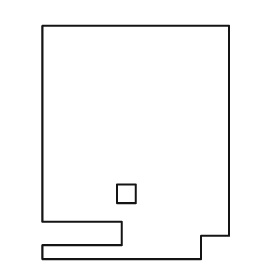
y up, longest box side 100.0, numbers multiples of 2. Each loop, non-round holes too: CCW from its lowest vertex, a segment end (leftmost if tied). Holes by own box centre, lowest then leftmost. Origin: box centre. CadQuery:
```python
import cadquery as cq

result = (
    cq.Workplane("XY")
    .moveTo(-40.0, -50.0)
    .lineTo(28.0, -50.0)
    .lineTo(28.0, -40.0)
    .lineTo(40.0, -40.0)
    .lineTo(40.0, 50.0)
    .lineTo(-40.0, 50.0)
    .lineTo(-40.0, -34.0)
    .lineTo(-6.0, -34.0)
    .lineTo(-6.0, -44.0)
    .lineTo(-40.0, -44.0)
    .close()
    .moveTo(-8.0, -26.0)
    .lineTo(0.0, -26.0)
    .lineTo(0.0, -18.0)
    .lineTo(-8.0, -18.0)
    .close()
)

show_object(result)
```